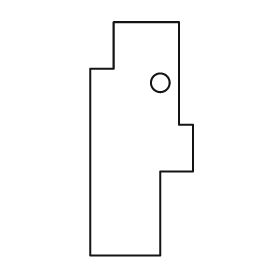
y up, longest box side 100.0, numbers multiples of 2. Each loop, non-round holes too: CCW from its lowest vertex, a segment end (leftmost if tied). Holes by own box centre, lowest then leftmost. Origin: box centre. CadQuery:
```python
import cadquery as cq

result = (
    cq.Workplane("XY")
    .moveTo(-22.0, -50.0)
    .lineTo(8.0, -50.0)
    .lineTo(8.0, -14.0)
    .lineTo(22.0, -14.0)
    .lineTo(22.0, 6.0)
    .lineTo(16.0, 6.0)
    .lineTo(16.0, 50.0)
    .lineTo(-12.0, 50.0)
    .lineTo(-12.0, 30.0)
    .lineTo(-22.0, 30.0)
    .close()
    .moveTo(8.0, 24.0)
    .circle(4.0)
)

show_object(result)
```